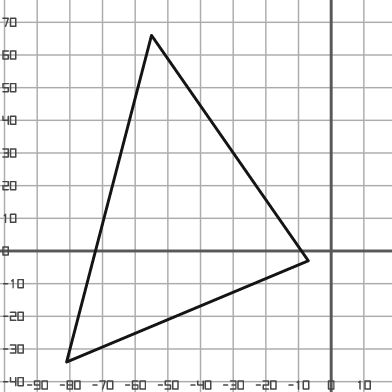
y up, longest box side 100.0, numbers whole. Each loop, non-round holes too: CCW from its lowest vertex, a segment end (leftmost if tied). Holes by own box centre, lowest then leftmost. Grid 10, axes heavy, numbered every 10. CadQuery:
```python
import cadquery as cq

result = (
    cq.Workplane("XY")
    .moveTo(-81.0, -34.0)
    .lineTo(-7.0, -3.0)
    .lineTo(-55.0, 66.0)
    .close()
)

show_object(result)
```